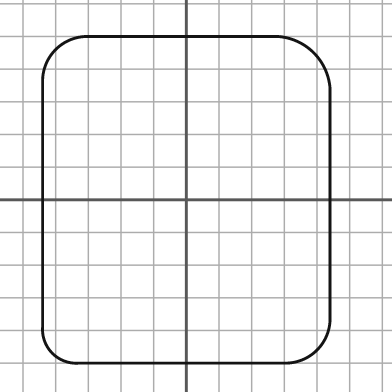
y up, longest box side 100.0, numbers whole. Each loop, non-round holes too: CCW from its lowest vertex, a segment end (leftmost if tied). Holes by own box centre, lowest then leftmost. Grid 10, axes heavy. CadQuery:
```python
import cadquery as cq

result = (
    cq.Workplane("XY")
    .moveTo(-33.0, -50.0)
    .lineTo(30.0, -50.0)
    .threePointArc((40.0, -46.0), (44.0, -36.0))
    .lineTo(44.0, 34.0)
    .threePointArc((39.0, 45.0), (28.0, 50.0))
    .lineTo(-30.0, 50.0)
    .threePointArc((-40.0, 46.0), (-44.0, 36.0))
    .lineTo(-44.0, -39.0)
    .threePointArc((-41.0, -47.0), (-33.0, -50.0))
    .close()
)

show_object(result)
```